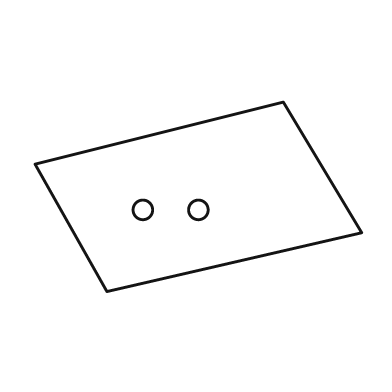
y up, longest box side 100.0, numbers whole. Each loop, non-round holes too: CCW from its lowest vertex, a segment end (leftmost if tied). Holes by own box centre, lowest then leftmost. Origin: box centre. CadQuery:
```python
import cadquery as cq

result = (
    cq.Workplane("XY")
    .moveTo(-28.0, -29.0)
    .lineTo(50.0, -11.0)
    .lineTo(26.0, 29.0)
    .lineTo(-50.0, 10.0)
    .close()
    .moveTo(-17.0, -4.0)
    .circle(3.0)
    .moveTo(0.0, -4.0)
    .circle(3.0)
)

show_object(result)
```